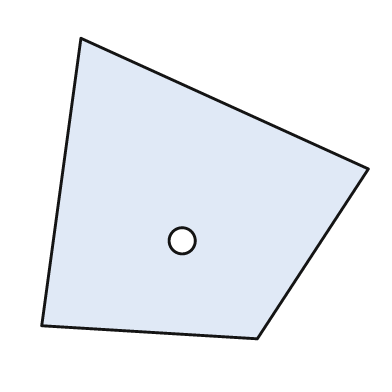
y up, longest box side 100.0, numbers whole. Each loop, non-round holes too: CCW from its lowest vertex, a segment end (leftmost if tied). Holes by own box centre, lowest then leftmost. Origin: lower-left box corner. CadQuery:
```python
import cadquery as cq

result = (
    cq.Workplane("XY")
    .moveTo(66.0, 0.0)
    .lineTo(100.0, 52.0)
    .lineTo(12.0, 92.0)
    .lineTo(0.0, 4.0)
    .close()
    .moveTo(43.0, 30.0)
    .circle(4.0)
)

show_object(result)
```